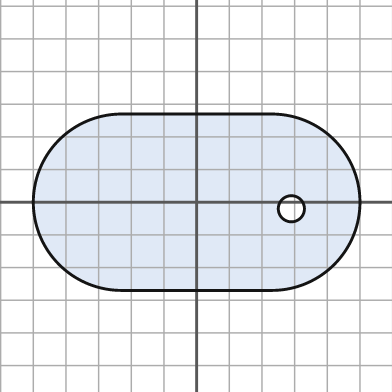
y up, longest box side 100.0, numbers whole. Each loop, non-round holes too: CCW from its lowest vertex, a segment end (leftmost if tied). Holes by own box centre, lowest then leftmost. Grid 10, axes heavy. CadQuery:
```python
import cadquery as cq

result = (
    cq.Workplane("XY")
    .moveTo(-23.0, -27.0)
    .lineTo(23.0, -27.0)
    .threePointArc((50.0, 0.0), (23.0, 27.0))
    .lineTo(-23.0, 27.0)
    .threePointArc((-50.0, 0.0), (-23.0, -27.0))
    .close()
    .moveTo(29.0, -2.0)
    .circle(4.0)
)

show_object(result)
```